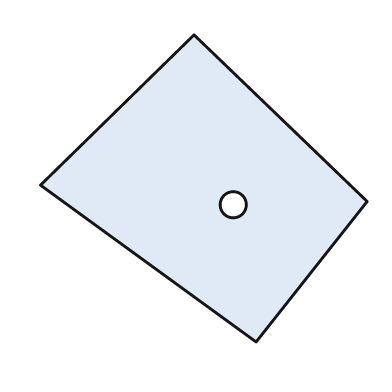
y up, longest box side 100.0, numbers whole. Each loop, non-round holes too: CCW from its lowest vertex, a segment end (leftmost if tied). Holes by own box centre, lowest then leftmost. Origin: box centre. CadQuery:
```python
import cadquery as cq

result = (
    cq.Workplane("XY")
    .moveTo(16.0, -47.0)
    .lineTo(50.0, -4.0)
    .lineTo(-3.0, 47.0)
    .lineTo(-50.0, 1.0)
    .close()
    .moveTo(9.0, -5.0)
    .circle(4.0)
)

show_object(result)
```